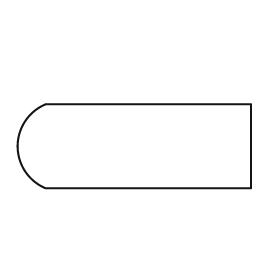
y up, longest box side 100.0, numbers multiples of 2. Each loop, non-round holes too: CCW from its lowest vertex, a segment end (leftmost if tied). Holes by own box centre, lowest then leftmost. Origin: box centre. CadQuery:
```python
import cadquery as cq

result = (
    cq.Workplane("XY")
    .moveTo(-38.0, -18.0)
    .lineTo(50.0, -18.0)
    .lineTo(50.0, 18.0)
    .lineTo(-38.0, 18.0)
    .threePointArc((-50.0, 0.0), (-38.0, -18.0))
    .close()
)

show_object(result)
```